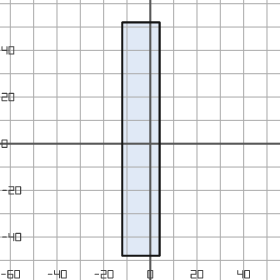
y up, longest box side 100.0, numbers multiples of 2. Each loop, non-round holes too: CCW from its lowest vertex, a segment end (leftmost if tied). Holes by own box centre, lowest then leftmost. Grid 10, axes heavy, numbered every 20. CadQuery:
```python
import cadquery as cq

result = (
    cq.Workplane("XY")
    .moveTo(-12.0, -48.0)
    .lineTo(4.0, -48.0)
    .lineTo(4.0, 52.0)
    .lineTo(-12.0, 52.0)
    .close()
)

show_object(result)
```